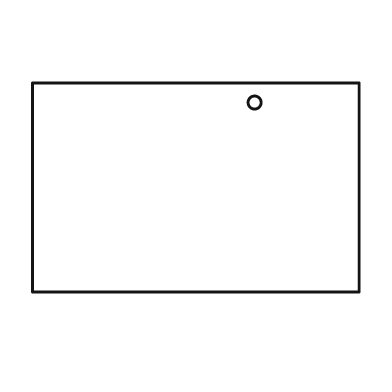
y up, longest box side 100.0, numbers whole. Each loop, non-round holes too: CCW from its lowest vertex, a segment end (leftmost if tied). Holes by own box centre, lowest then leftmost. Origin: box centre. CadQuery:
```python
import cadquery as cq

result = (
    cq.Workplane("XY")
    .moveTo(-50.0, -32.0)
    .lineTo(50.0, -32.0)
    .lineTo(50.0, 32.0)
    .lineTo(-50.0, 32.0)
    .close()
    .moveTo(18.0, 26.0)
    .circle(2.0)
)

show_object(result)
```